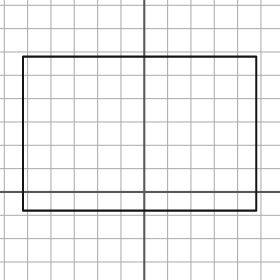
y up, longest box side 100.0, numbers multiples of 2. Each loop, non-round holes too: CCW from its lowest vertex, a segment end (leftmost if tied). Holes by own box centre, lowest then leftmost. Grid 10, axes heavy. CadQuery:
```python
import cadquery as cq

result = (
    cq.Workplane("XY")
    .moveTo(-52.0, -8.0)
    .lineTo(48.0, -8.0)
    .lineTo(48.0, 58.0)
    .lineTo(-52.0, 58.0)
    .close()
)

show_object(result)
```